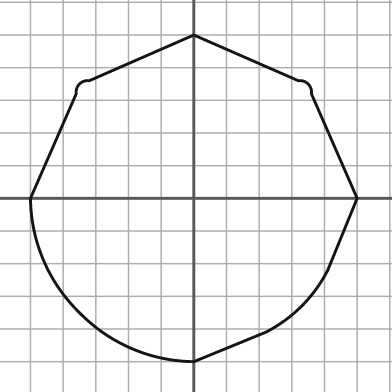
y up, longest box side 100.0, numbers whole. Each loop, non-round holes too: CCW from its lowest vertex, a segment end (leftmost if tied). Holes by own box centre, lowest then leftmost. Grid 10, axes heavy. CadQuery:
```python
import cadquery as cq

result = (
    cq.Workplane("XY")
    .moveTo(0.0, -50.0)
    .lineTo(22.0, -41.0)
    .threePointArc((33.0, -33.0), (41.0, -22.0))
    .lineTo(50.0, 0.0)
    .lineTo(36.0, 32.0)
    .threePointArc((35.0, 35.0), (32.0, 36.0))
    .lineTo(0.0, 50.0)
    .lineTo(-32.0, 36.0)
    .threePointArc((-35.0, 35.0), (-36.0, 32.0))
    .lineTo(-50.0, 0.0)
    .threePointArc((-46.0, -19.0), (-35.0, -35.0))
    .threePointArc((-19.0, -46.0), (0.0, -50.0))
    .close()
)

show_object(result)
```